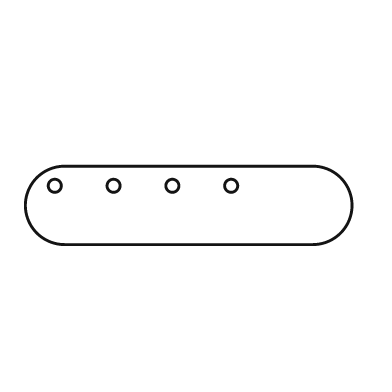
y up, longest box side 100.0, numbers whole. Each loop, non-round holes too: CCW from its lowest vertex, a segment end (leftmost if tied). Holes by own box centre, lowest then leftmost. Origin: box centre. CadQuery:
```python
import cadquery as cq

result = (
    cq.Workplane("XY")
    .moveTo(-38.0, -12.0)
    .lineTo(38.0, -12.0)
    .threePointArc((50.0, 0.0), (38.0, 12.0))
    .lineTo(-38.0, 12.0)
    .threePointArc((-50.0, 0.0), (-38.0, -12.0))
    .close()
    .moveTo(-41.0, 6.0)
    .circle(2.0)
    .moveTo(-23.0, 6.0)
    .circle(2.0)
    .moveTo(-5.0, 6.0)
    .circle(2.0)
    .moveTo(13.0, 6.0)
    .circle(2.0)
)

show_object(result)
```